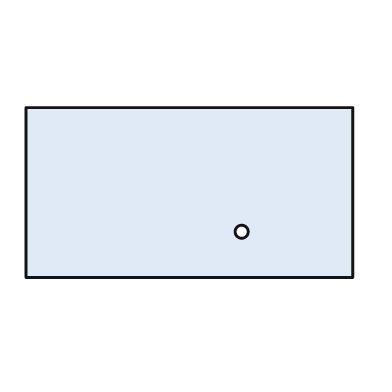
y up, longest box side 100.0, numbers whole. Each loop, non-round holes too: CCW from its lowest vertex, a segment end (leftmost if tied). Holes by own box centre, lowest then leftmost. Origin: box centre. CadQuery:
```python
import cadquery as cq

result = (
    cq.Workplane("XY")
    .moveTo(-50.0, -26.0)
    .lineTo(50.0, -26.0)
    .lineTo(50.0, 26.0)
    .lineTo(-50.0, 26.0)
    .close()
    .moveTo(16.0, -12.0)
    .circle(2.0)
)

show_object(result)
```